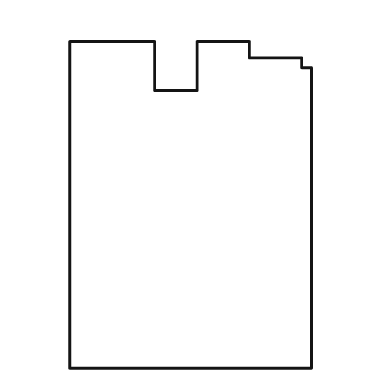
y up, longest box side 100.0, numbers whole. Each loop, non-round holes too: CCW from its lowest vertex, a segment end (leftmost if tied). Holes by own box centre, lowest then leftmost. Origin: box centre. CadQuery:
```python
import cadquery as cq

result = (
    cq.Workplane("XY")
    .moveTo(-37.0, -50.0)
    .lineTo(37.0, -50.0)
    .lineTo(37.0, 42.0)
    .lineTo(34.0, 42.0)
    .lineTo(34.0, 45.0)
    .lineTo(18.0, 45.0)
    .lineTo(18.0, 50.0)
    .lineTo(2.0, 50.0)
    .lineTo(2.0, 35.0)
    .lineTo(-11.0, 35.0)
    .lineTo(-11.0, 50.0)
    .lineTo(-37.0, 50.0)
    .close()
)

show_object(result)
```